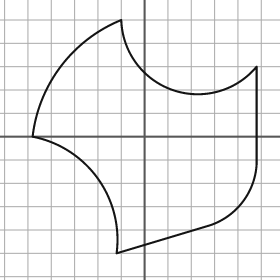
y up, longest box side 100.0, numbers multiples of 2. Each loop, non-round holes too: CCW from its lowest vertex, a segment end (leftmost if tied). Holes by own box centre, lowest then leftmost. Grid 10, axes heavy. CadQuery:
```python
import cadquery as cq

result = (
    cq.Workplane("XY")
    .moveTo(-12.0, -50.0)
    .lineTo(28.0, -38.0)
    .threePointArc((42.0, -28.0), (48.0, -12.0))
    .lineTo(48.0, 30.0)
    .threePointArc((12.0, 20.0), (-10.0, 50.0))
    .threePointArc((-36.0, 30.0), (-48.0, 0.0))
    .threePointArc((-20.0, -18.0), (-12.0, -50.0))
    .close()
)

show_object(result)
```